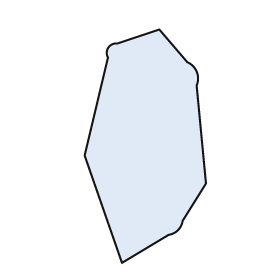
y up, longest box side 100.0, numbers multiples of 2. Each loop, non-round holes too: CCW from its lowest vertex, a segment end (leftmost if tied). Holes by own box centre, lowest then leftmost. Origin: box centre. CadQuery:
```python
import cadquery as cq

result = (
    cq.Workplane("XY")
    .moveTo(-10.0, -50.0)
    .lineTo(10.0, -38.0)
    .threePointArc((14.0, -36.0), (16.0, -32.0))
    .lineTo(26.0, -16.0)
    .lineTo(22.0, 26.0)
    .threePointArc((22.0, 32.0), (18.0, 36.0))
    .lineTo(6.0, 50.0)
    .lineTo(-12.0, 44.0)
    .threePointArc((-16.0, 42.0), (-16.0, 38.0))
    .lineTo(-26.0, -4.0)
    .close()
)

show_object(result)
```